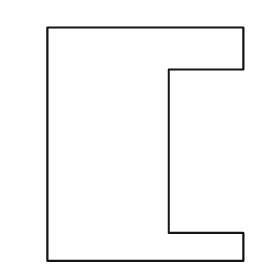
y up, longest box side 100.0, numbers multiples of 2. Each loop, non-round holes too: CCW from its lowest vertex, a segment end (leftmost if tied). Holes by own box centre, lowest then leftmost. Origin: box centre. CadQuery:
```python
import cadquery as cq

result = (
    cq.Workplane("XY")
    .moveTo(-42.0, -50.0)
    .lineTo(42.0, -50.0)
    .lineTo(42.0, -38.0)
    .lineTo(10.0, -38.0)
    .lineTo(10.0, 32.0)
    .lineTo(42.0, 32.0)
    .lineTo(42.0, 50.0)
    .lineTo(-42.0, 50.0)
    .close()
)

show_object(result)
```